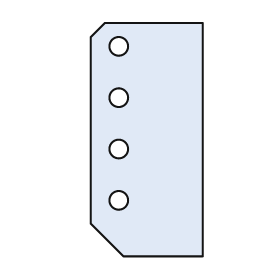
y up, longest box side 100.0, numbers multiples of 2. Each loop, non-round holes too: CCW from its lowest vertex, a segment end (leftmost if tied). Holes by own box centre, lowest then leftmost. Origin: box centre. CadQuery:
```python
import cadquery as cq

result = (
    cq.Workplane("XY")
    .moveTo(-10.0, -50.0)
    .lineTo(24.0, -50.0)
    .lineTo(24.0, 50.0)
    .lineTo(-18.0, 50.0)
    .lineTo(-24.0, 44.0)
    .lineTo(-24.0, -36.0)
    .close()
    .moveTo(-12.0, -26.0)
    .circle(4.0)
    .moveTo(-12.0, -4.0)
    .circle(4.0)
    .moveTo(-12.0, 18.0)
    .circle(4.0)
    .moveTo(-12.0, 40.0)
    .circle(4.0)
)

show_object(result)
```